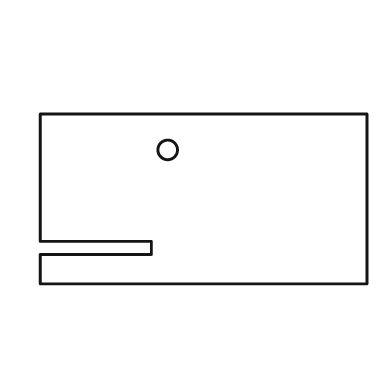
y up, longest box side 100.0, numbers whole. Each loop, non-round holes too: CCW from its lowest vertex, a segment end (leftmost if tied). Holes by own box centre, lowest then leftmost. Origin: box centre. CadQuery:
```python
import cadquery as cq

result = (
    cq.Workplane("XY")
    .moveTo(-50.0, -26.0)
    .lineTo(50.0, -26.0)
    .lineTo(50.0, 26.0)
    .lineTo(-50.0, 26.0)
    .lineTo(-50.0, -13.0)
    .lineTo(-16.0, -13.0)
    .lineTo(-16.0, -17.0)
    .lineTo(-50.0, -17.0)
    .close()
    .moveTo(-11.0, 15.0)
    .circle(3.0)
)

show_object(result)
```